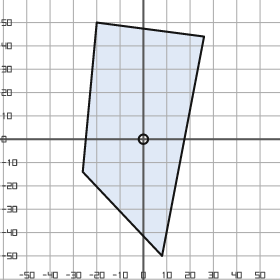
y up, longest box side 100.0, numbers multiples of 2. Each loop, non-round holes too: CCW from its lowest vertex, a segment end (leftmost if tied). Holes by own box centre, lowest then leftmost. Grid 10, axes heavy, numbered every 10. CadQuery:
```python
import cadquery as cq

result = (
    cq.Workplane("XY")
    .moveTo(8.0, -50.0)
    .lineTo(26.0, 44.0)
    .lineTo(-20.0, 50.0)
    .lineTo(-26.0, -14.0)
    .close()
    .moveTo(0.0, 0.0)
    .circle(2.0)
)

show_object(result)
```